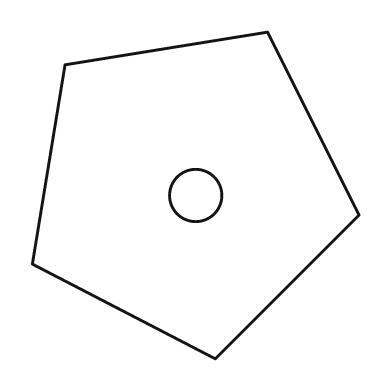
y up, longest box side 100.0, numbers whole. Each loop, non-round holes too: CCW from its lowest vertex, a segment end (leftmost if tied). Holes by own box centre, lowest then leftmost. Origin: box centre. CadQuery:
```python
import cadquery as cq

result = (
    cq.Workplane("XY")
    .moveTo(6.0, -50.0)
    .lineTo(50.0, -6.0)
    .lineTo(22.0, 50.0)
    .lineTo(-40.0, 40.0)
    .lineTo(-50.0, -21.0)
    .close()
    .moveTo(0.0, 0.0)
    .circle(8.0)
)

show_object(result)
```